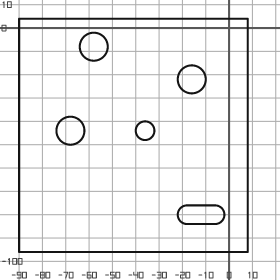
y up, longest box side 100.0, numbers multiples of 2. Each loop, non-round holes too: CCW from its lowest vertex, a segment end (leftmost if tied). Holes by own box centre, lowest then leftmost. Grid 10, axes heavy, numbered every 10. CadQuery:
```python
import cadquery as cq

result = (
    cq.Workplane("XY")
    .moveTo(-90.0, -96.0)
    .lineTo(8.0, -96.0)
    .lineTo(8.0, 4.0)
    .lineTo(-90.0, 4.0)
    .close()
    .moveTo(-18.0, -84.0)
    .lineTo(-6.0, -84.0)
    .threePointArc((-2.0, -80.0), (-6.0, -76.0))
    .lineTo(-18.0, -76.0)
    .threePointArc((-22.0, -80.0), (-18.0, -84.0))
    .close()
    .moveTo(-68.0, -44.0)
    .circle(6.0)
    .moveTo(-36.0, -44.0)
    .circle(4.0)
    .moveTo(-16.0, -22.0)
    .circle(6.0)
    .moveTo(-58.0, -8.0)
    .circle(6.0)
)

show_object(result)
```